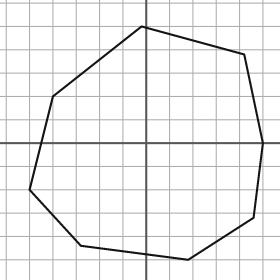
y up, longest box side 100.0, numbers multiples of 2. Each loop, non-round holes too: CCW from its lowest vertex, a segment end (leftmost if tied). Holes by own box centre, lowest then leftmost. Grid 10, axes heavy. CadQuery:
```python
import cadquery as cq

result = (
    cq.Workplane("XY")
    .moveTo(18.0, -50.0)
    .lineTo(46.0, -32.0)
    .lineTo(50.0, 0.0)
    .lineTo(42.0, 38.0)
    .lineTo(-2.0, 50.0)
    .lineTo(-40.0, 20.0)
    .lineTo(-50.0, -20.0)
    .lineTo(-28.0, -44.0)
    .close()
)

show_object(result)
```